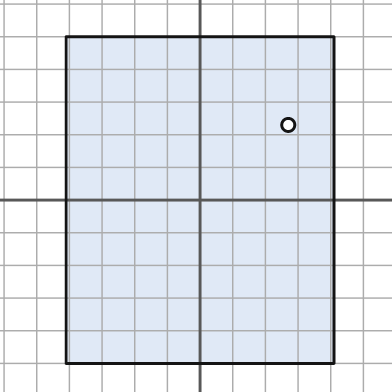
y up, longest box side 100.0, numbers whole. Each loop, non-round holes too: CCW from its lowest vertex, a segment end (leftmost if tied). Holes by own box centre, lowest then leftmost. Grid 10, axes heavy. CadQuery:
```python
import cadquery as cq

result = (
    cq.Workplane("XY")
    .moveTo(-41.0, -50.0)
    .lineTo(41.0, -50.0)
    .lineTo(41.0, 50.0)
    .lineTo(-41.0, 50.0)
    .close()
    .moveTo(27.0, 23.0)
    .circle(2.0)
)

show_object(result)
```